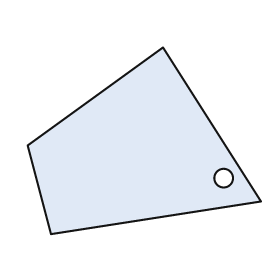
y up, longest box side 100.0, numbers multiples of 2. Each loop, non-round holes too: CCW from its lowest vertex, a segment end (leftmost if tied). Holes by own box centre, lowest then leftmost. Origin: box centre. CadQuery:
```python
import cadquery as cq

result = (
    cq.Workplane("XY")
    .moveTo(-40.0, -40.0)
    .lineTo(50.0, -26.0)
    .lineTo(8.0, 40.0)
    .lineTo(-50.0, -2.0)
    .close()
    .moveTo(34.0, -16.0)
    .circle(4.0)
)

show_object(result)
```